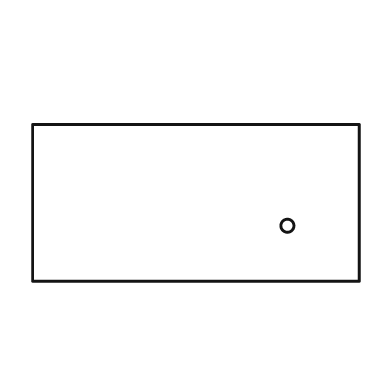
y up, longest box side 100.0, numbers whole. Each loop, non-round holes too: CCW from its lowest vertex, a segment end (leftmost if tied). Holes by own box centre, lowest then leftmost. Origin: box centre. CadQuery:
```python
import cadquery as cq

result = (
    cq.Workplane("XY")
    .moveTo(-50.0, -24.0)
    .lineTo(50.0, -24.0)
    .lineTo(50.0, 24.0)
    .lineTo(-50.0, 24.0)
    .close()
    .moveTo(28.0, -7.0)
    .circle(2.0)
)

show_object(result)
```